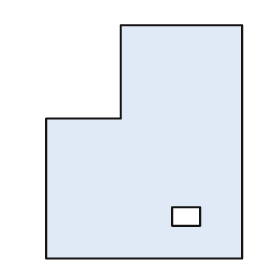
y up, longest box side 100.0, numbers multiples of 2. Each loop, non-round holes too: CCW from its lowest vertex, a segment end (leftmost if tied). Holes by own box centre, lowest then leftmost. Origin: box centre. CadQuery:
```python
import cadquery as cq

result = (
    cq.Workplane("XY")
    .moveTo(-42.0, -50.0)
    .lineTo(42.0, -50.0)
    .lineTo(42.0, 50.0)
    .lineTo(-10.0, 50.0)
    .lineTo(-10.0, 10.0)
    .lineTo(-42.0, 10.0)
    .close()
    .moveTo(12.0, -36.0)
    .lineTo(24.0, -36.0)
    .lineTo(24.0, -28.0)
    .lineTo(12.0, -28.0)
    .close()
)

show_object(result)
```